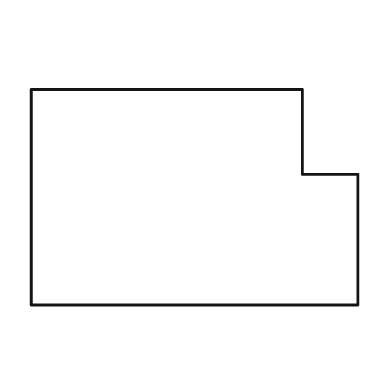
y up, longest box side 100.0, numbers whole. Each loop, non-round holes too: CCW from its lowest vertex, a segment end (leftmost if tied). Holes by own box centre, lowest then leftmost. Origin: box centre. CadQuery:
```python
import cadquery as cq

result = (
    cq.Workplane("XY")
    .moveTo(-50.0, -33.0)
    .lineTo(50.0, -33.0)
    .lineTo(50.0, 7.0)
    .lineTo(33.0, 7.0)
    .lineTo(33.0, 33.0)
    .lineTo(-50.0, 33.0)
    .close()
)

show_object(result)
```